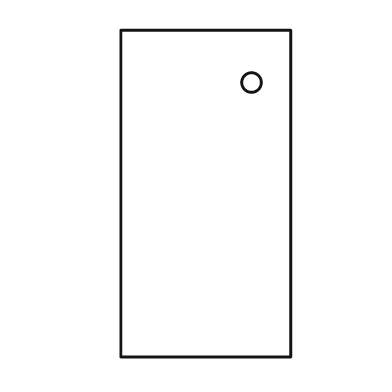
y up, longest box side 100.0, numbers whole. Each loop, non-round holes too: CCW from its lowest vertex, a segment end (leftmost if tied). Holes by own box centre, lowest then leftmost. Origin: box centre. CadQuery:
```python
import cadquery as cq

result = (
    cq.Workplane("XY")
    .moveTo(-26.0, -50.0)
    .lineTo(26.0, -50.0)
    .lineTo(26.0, 50.0)
    .lineTo(-26.0, 50.0)
    .close()
    .moveTo(14.0, 34.0)
    .circle(3.0)
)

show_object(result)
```